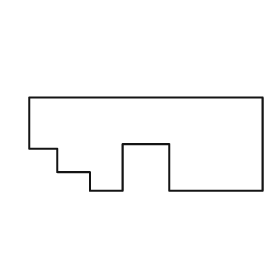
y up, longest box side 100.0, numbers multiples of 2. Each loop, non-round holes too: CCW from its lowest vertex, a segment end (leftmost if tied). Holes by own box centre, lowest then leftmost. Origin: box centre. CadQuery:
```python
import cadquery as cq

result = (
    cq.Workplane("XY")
    .moveTo(-24.0, -20.0)
    .lineTo(-10.0, -20.0)
    .lineTo(-10.0, 0.0)
    .lineTo(10.0, 0.0)
    .lineTo(10.0, -20.0)
    .lineTo(50.0, -20.0)
    .lineTo(50.0, 20.0)
    .lineTo(-50.0, 20.0)
    .lineTo(-50.0, -2.0)
    .lineTo(-38.0, -2.0)
    .lineTo(-38.0, -12.0)
    .lineTo(-24.0, -12.0)
    .close()
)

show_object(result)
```